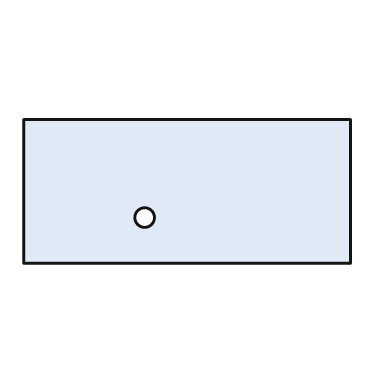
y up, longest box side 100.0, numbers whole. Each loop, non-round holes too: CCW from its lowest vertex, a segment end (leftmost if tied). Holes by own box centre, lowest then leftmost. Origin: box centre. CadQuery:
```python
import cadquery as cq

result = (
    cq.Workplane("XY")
    .moveTo(-50.0, -22.0)
    .lineTo(50.0, -22.0)
    .lineTo(50.0, 22.0)
    .lineTo(-50.0, 22.0)
    .close()
    .moveTo(-13.0, -8.0)
    .circle(3.0)
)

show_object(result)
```